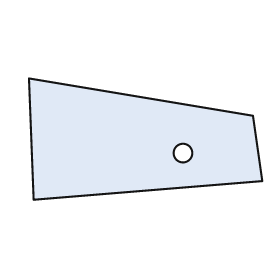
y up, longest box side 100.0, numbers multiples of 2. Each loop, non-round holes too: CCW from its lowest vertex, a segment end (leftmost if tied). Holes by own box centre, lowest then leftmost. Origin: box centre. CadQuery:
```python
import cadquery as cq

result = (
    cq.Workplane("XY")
    .moveTo(-48.0, -26.0)
    .lineTo(50.0, -18.0)
    .lineTo(46.0, 10.0)
    .lineTo(-50.0, 26.0)
    .close()
    .moveTo(16.0, -6.0)
    .circle(4.0)
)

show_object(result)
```